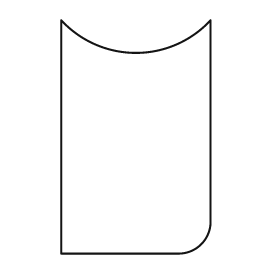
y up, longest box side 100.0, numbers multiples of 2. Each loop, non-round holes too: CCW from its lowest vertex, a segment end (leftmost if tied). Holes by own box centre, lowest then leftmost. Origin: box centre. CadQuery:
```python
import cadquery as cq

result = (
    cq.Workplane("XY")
    .moveTo(-32.0, -50.0)
    .lineTo(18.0, -50.0)
    .threePointArc((28.0, -46.0), (32.0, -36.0))
    .lineTo(32.0, 50.0)
    .threePointArc((0.0, 36.0), (-32.0, 50.0))
    .close()
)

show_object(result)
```